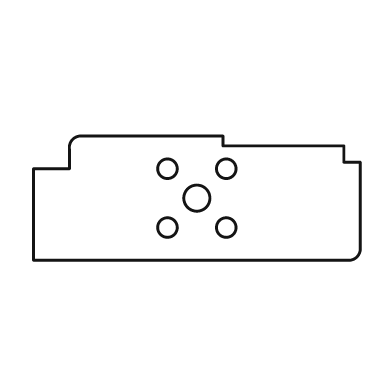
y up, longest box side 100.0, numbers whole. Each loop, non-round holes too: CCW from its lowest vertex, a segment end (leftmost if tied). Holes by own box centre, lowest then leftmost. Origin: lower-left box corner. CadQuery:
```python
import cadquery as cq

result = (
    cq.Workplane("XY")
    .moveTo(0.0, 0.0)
    .lineTo(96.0, 0.0)
    .threePointArc((99.0, 1.0), (100.0, 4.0))
    .lineTo(100.0, 30.0)
    .lineTo(95.0, 30.0)
    .lineTo(95.0, 35.0)
    .lineTo(58.0, 35.0)
    .lineTo(58.0, 38.0)
    .lineTo(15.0, 38.0)
    .threePointArc((12.0, 37.0), (11.0, 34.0))
    .lineTo(11.0, 28.0)
    .lineTo(0.0, 28.0)
    .close()
    .moveTo(41.0, 10.0)
    .circle(3.0)
    .moveTo(59.0, 10.0)
    .circle(3.0)
    .moveTo(50.0, 19.0)
    .circle(4.0)
    .moveTo(41.0, 28.0)
    .circle(3.0)
    .moveTo(59.0, 28.0)
    .circle(3.0)
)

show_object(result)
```